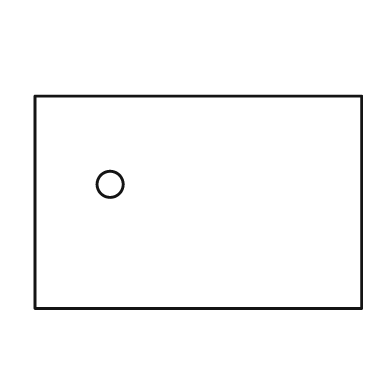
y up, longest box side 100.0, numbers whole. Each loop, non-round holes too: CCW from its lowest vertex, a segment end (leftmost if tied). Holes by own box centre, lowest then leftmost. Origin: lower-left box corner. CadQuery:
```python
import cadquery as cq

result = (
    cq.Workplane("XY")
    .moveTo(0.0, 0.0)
    .lineTo(100.0, 0.0)
    .lineTo(100.0, 65.0)
    .lineTo(0.0, 65.0)
    .close()
    .moveTo(23.0, 38.0)
    .circle(4.0)
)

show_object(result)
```